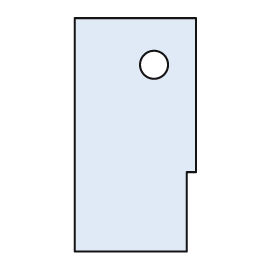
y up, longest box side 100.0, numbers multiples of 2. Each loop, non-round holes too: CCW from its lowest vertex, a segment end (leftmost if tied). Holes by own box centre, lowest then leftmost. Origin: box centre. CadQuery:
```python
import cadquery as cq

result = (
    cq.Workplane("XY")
    .moveTo(-26.0, -50.0)
    .lineTo(22.0, -50.0)
    .lineTo(22.0, -16.0)
    .lineTo(26.0, -16.0)
    .lineTo(26.0, 50.0)
    .lineTo(-26.0, 50.0)
    .close()
    .moveTo(8.0, 30.0)
    .circle(6.0)
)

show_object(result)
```